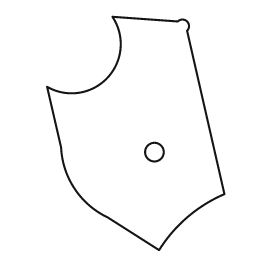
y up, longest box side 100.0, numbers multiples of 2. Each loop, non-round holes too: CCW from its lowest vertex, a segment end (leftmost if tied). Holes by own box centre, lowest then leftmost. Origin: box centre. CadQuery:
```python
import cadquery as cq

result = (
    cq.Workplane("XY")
    .moveTo(10.0, -50.0)
    .threePointArc((22.0, -36.0), (38.0, -26.0))
    .lineTo(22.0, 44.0)
    .threePointArc((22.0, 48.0), (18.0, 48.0))
    .lineTo(-10.0, 50.0)
    .threePointArc((-12.0, 24.0), (-38.0, 20.0))
    .lineTo(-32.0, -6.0)
    .threePointArc((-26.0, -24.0), (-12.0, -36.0))
    .close()
    .moveTo(8.0, -8.0)
    .circle(4.0)
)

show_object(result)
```